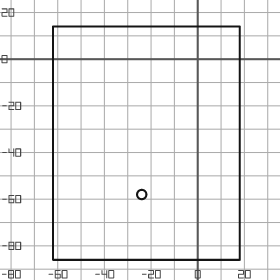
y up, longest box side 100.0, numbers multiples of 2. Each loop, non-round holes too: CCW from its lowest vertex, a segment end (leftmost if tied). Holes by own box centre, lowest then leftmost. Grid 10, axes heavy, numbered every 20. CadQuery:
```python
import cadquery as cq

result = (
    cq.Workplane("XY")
    .moveTo(-62.0, -86.0)
    .lineTo(18.0, -86.0)
    .lineTo(18.0, 14.0)
    .lineTo(-62.0, 14.0)
    .close()
    .moveTo(-24.0, -58.0)
    .circle(2.0)
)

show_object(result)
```